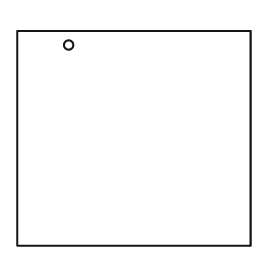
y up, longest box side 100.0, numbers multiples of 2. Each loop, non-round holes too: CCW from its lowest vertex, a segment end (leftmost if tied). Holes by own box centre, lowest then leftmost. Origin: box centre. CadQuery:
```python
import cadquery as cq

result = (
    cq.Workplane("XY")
    .moveTo(-50.0, -46.0)
    .lineTo(50.0, -46.0)
    .lineTo(50.0, 46.0)
    .lineTo(-50.0, 46.0)
    .close()
    .moveTo(-28.0, 40.0)
    .circle(2.0)
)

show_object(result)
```